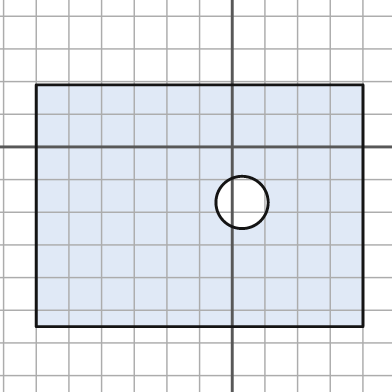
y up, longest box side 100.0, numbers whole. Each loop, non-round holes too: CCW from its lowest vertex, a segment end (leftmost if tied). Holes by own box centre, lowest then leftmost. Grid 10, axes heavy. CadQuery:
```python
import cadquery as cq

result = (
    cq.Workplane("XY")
    .moveTo(-60.0, -55.0)
    .lineTo(40.0, -55.0)
    .lineTo(40.0, 19.0)
    .lineTo(-60.0, 19.0)
    .close()
    .moveTo(3.0, -17.0)
    .circle(8.0)
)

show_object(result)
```